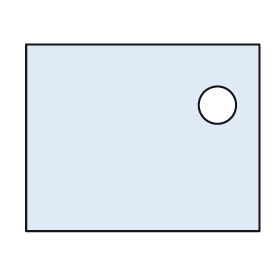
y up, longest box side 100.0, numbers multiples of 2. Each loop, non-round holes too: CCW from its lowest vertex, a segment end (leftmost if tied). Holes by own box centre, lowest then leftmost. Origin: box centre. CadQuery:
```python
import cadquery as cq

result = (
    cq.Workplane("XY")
    .moveTo(-50.0, -40.0)
    .lineTo(50.0, -40.0)
    .lineTo(50.0, 40.0)
    .lineTo(-50.0, 40.0)
    .close()
    .moveTo(32.0, 14.0)
    .circle(8.0)
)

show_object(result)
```